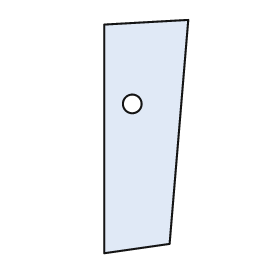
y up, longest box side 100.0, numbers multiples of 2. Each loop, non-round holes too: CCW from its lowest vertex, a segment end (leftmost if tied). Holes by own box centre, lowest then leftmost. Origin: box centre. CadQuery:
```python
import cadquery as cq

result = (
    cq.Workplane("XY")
    .moveTo(-18.0, -50.0)
    .lineTo(10.0, -46.0)
    .lineTo(18.0, 50.0)
    .lineTo(-18.0, 48.0)
    .close()
    .moveTo(-6.0, 14.0)
    .circle(4.0)
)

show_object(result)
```